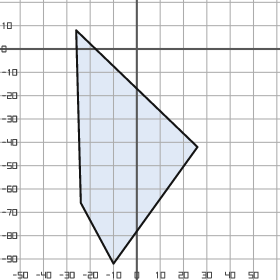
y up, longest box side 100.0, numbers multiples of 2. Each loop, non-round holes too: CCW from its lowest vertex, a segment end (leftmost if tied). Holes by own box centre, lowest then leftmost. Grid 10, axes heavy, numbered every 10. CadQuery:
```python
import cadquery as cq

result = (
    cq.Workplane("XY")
    .moveTo(-10.0, -92.0)
    .lineTo(26.0, -42.0)
    .lineTo(-26.0, 8.0)
    .lineTo(-24.0, -66.0)
    .close()
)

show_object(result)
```